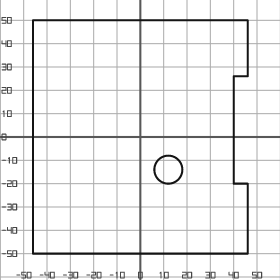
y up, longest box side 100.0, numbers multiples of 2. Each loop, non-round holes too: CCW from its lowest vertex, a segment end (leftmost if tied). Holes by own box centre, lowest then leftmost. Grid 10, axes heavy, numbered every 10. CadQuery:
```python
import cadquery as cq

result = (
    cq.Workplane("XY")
    .moveTo(-46.0, -50.0)
    .lineTo(46.0, -50.0)
    .lineTo(46.0, -20.0)
    .lineTo(40.0, -20.0)
    .lineTo(40.0, 26.0)
    .lineTo(46.0, 26.0)
    .lineTo(46.0, 50.0)
    .lineTo(-46.0, 50.0)
    .close()
    .moveTo(12.0, -14.0)
    .circle(6.0)
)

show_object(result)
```